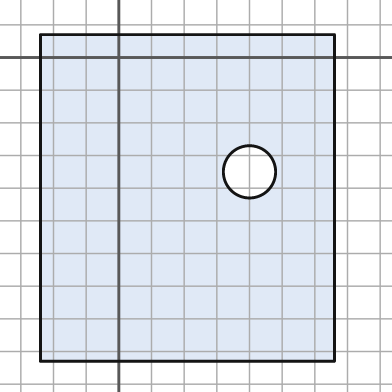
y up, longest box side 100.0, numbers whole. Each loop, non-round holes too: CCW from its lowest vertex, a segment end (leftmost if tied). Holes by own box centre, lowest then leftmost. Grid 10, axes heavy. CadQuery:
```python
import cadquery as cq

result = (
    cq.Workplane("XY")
    .moveTo(-24.0, -93.0)
    .lineTo(66.0, -93.0)
    .lineTo(66.0, 7.0)
    .lineTo(-24.0, 7.0)
    .close()
    .moveTo(40.0, -35.0)
    .circle(8.0)
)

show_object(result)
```